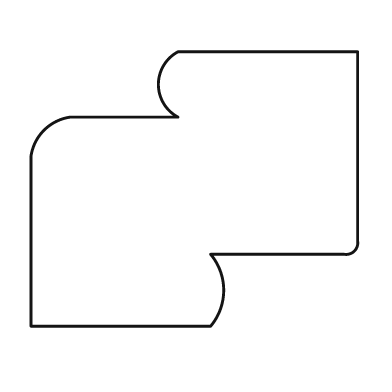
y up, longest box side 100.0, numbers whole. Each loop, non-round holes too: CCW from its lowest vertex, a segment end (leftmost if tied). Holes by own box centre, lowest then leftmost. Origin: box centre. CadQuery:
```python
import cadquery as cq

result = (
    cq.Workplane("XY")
    .moveTo(-50.0, -42.0)
    .lineTo(5.0, -42.0)
    .threePointArc((9.0, -31.0), (5.0, -20.0))
    .lineTo(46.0, -20.0)
    .threePointArc((49.0, -19.0), (50.0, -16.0))
    .lineTo(50.0, 42.0)
    .lineTo(-5.0, 42.0)
    .threePointArc((-11.0, 32.0), (-5.0, 22.0))
    .lineTo(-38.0, 22.0)
    .threePointArc((-46.0, 18.0), (-50.0, 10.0))
    .close()
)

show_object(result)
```